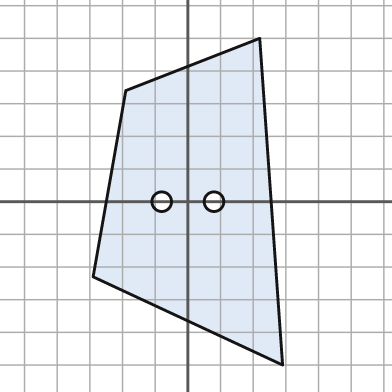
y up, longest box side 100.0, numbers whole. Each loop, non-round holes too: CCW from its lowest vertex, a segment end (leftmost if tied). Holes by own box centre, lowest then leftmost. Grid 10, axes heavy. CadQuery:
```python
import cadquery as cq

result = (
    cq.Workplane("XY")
    .moveTo(29.0, -50.0)
    .lineTo(22.0, 50.0)
    .lineTo(-19.0, 34.0)
    .lineTo(-29.0, -23.0)
    .close()
    .moveTo(-8.0, 0.0)
    .circle(3.0)
    .moveTo(8.0, 0.0)
    .circle(3.0)
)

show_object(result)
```